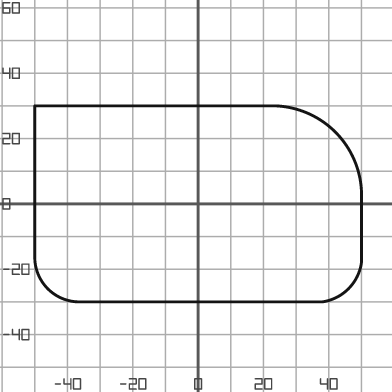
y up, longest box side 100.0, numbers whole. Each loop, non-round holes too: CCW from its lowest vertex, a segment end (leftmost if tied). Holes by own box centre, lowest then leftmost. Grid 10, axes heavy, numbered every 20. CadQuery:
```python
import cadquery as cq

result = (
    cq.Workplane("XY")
    .moveTo(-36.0, -30.0)
    .lineTo(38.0, -30.0)
    .threePointArc((46.0, -26.0), (50.0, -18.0))
    .lineTo(50.0, 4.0)
    .threePointArc((42.0, 22.0), (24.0, 30.0))
    .lineTo(-50.0, 30.0)
    .lineTo(-50.0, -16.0)
    .threePointArc((-46.0, -26.0), (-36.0, -30.0))
    .close()
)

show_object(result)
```